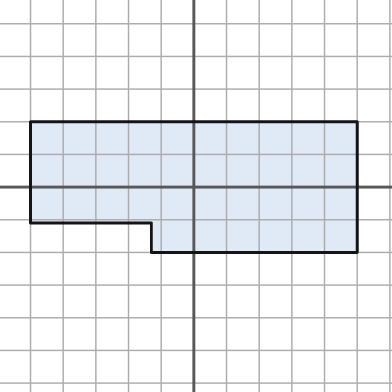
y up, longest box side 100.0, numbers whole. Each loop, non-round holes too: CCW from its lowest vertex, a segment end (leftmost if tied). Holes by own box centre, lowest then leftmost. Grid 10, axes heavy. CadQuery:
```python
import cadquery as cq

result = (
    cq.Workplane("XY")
    .moveTo(-13.0, -20.0)
    .lineTo(50.0, -20.0)
    .lineTo(50.0, 20.0)
    .lineTo(-50.0, 20.0)
    .lineTo(-50.0, -11.0)
    .lineTo(-13.0, -11.0)
    .close()
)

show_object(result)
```